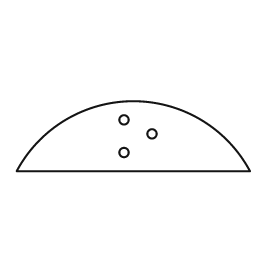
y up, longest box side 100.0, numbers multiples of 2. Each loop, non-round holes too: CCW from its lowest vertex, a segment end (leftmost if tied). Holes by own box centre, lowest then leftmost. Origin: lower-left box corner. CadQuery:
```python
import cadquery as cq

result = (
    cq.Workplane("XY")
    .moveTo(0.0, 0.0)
    .lineTo(100.0, 0.0)
    .threePointArc((50.0, 30.0), (0.0, 0.0))
    .close()
    .moveTo(46.0, 8.0)
    .circle(2.0)
    .moveTo(58.0, 16.0)
    .circle(2.0)
    .moveTo(46.0, 22.0)
    .circle(2.0)
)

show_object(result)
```